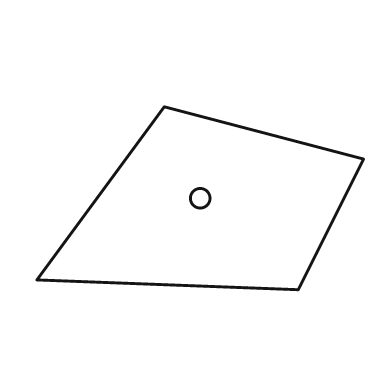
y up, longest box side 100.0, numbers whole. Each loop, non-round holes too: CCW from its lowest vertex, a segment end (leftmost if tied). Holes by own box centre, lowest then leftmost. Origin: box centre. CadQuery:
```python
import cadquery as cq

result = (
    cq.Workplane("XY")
    .moveTo(30.0, -28.0)
    .lineTo(50.0, 12.0)
    .lineTo(-11.0, 28.0)
    .lineTo(-50.0, -25.0)
    .close()
    .moveTo(0.0, 0.0)
    .circle(3.0)
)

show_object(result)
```